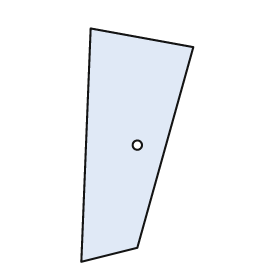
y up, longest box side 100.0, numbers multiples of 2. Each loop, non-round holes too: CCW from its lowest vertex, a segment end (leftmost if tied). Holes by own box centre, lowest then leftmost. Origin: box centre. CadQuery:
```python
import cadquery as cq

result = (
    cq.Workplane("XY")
    .moveTo(-24.0, -50.0)
    .lineTo(0.0, -44.0)
    .lineTo(24.0, 42.0)
    .lineTo(-20.0, 50.0)
    .close()
    .moveTo(0.0, 0.0)
    .circle(2.0)
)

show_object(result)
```